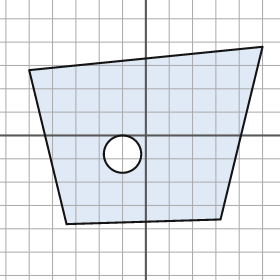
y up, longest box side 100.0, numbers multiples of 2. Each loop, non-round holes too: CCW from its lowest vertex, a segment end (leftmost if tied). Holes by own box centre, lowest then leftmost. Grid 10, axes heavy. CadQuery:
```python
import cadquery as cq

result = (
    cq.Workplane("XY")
    .moveTo(-34.0, -38.0)
    .lineTo(32.0, -36.0)
    .lineTo(50.0, 38.0)
    .lineTo(-50.0, 28.0)
    .close()
    .moveTo(-10.0, -8.0)
    .circle(8.0)
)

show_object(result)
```